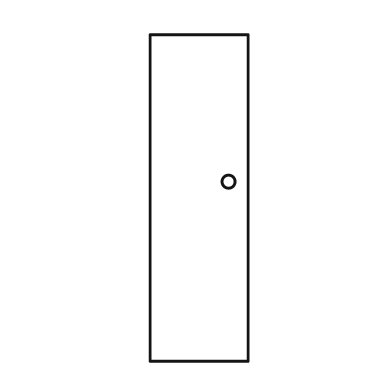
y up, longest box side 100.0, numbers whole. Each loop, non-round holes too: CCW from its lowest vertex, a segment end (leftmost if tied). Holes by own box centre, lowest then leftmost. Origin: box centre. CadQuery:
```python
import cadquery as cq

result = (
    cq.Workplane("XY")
    .moveTo(-15.0, -50.0)
    .lineTo(15.0, -50.0)
    .lineTo(15.0, 50.0)
    .lineTo(-15.0, 50.0)
    .close()
    .moveTo(9.0, 5.0)
    .circle(2.0)
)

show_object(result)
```